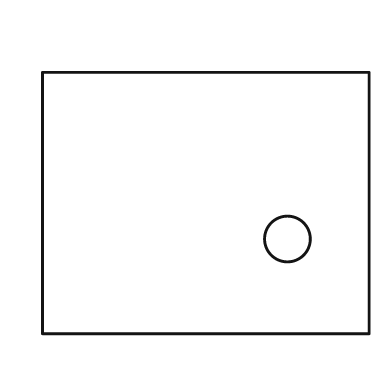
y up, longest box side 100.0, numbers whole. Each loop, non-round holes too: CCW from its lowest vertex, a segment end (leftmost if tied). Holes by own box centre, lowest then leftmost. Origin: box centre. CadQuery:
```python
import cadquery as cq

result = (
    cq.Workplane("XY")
    .moveTo(-50.0, -40.0)
    .lineTo(50.0, -40.0)
    .lineTo(50.0, 40.0)
    .lineTo(-50.0, 40.0)
    .close()
    .moveTo(25.0, -11.0)
    .circle(7.0)
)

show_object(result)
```